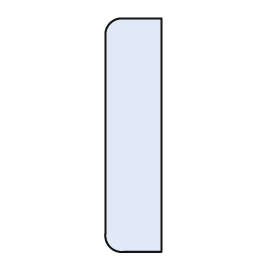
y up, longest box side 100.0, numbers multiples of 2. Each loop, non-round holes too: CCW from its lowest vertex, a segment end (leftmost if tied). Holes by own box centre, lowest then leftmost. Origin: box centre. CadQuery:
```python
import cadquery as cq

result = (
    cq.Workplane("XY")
    .moveTo(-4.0, -50.0)
    .lineTo(12.0, -50.0)
    .lineTo(12.0, 50.0)
    .lineTo(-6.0, 50.0)
    .threePointArc((-10.0, 48.0), (-12.0, 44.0))
    .lineTo(-12.0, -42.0)
    .threePointArc((-10.0, -48.0), (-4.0, -50.0))
    .close()
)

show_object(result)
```